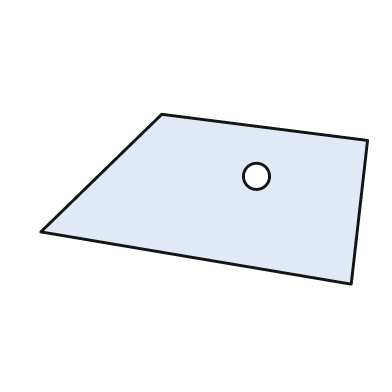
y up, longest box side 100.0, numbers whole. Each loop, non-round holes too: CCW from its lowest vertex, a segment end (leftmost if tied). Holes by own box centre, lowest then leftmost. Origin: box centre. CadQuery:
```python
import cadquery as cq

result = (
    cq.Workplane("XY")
    .moveTo(45.0, -26.0)
    .lineTo(50.0, 18.0)
    .lineTo(-13.0, 26.0)
    .lineTo(-50.0, -10.0)
    .close()
    .moveTo(16.0, 7.0)
    .circle(4.0)
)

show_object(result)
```